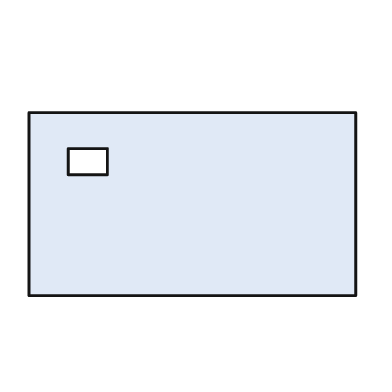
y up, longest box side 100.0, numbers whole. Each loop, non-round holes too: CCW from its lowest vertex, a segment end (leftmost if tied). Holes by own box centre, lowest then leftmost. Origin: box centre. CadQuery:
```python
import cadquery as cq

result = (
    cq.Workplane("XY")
    .moveTo(-50.0, -28.0)
    .lineTo(50.0, -28.0)
    .lineTo(50.0, 28.0)
    .lineTo(-50.0, 28.0)
    .close()
    .moveTo(-38.0, 9.0)
    .lineTo(-26.0, 9.0)
    .lineTo(-26.0, 17.0)
    .lineTo(-38.0, 17.0)
    .close()
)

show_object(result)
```